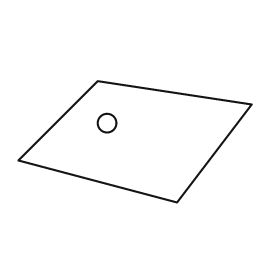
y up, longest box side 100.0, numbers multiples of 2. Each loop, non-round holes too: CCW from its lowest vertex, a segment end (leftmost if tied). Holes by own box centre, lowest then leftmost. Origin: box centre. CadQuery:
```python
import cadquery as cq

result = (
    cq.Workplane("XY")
    .moveTo(18.0, -26.0)
    .lineTo(50.0, 16.0)
    .lineTo(-16.0, 26.0)
    .lineTo(-50.0, -8.0)
    .close()
    .moveTo(-12.0, 8.0)
    .circle(4.0)
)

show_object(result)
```